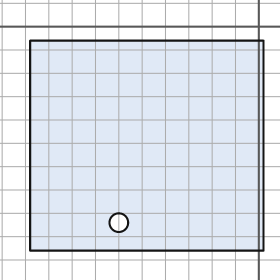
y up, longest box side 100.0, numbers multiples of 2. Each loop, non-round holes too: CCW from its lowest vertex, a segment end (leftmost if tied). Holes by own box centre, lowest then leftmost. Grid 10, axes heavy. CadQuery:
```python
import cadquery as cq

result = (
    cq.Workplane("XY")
    .moveTo(-98.0, -96.0)
    .lineTo(2.0, -96.0)
    .lineTo(2.0, -6.0)
    .lineTo(-98.0, -6.0)
    .close()
    .moveTo(-60.0, -84.0)
    .circle(4.0)
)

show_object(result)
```